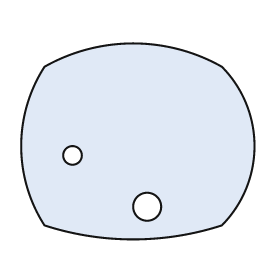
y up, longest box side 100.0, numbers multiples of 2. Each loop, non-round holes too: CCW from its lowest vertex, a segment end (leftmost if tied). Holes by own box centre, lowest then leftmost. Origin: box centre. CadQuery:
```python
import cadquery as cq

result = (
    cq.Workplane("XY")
    .moveTo(-40.0, -36.0)
    .threePointArc((-2.0, -42.0), (36.0, -36.0))
    .threePointArc((50.0, -2.0), (36.0, 32.0))
    .threePointArc((-2.0, 42.0), (-40.0, 32.0))
    .threePointArc((-50.0, -2.0), (-40.0, -36.0))
    .close()
    .moveTo(4.0, -28.0)
    .circle(6.0)
    .moveTo(-28.0, -6.0)
    .circle(4.0)
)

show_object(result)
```